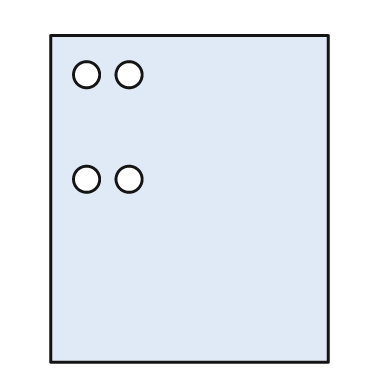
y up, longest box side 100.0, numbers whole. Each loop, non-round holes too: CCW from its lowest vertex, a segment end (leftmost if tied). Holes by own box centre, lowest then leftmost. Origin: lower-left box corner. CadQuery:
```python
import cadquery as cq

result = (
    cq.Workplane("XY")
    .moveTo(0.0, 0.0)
    .lineTo(85.0, 0.0)
    .lineTo(85.0, 100.0)
    .lineTo(0.0, 100.0)
    .close()
    .moveTo(11.0, 56.0)
    .circle(4.0)
    .moveTo(24.0, 56.0)
    .circle(4.0)
    .moveTo(11.0, 88.0)
    .circle(4.0)
    .moveTo(24.0, 88.0)
    .circle(4.0)
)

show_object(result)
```